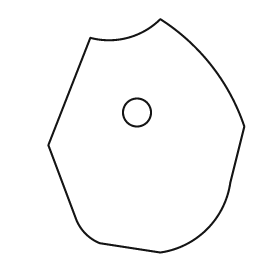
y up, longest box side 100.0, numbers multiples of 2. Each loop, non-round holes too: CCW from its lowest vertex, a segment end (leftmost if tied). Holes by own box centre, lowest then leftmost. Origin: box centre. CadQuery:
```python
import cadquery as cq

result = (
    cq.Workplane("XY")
    .moveTo(6.0, -50.0)
    .threePointArc((26.0, -40.0), (36.0, -20.0))
    .lineTo(42.0, 4.0)
    .threePointArc((28.0, 30.0), (6.0, 50.0))
    .threePointArc((-8.0, 42.0), (-24.0, 42.0))
    .lineTo(-42.0, -4.0)
    .lineTo(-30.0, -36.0)
    .threePointArc((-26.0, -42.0), (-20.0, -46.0))
    .close()
    .moveTo(-4.0, 10.0)
    .circle(6.0)
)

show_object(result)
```